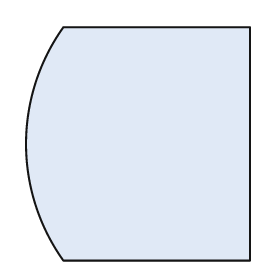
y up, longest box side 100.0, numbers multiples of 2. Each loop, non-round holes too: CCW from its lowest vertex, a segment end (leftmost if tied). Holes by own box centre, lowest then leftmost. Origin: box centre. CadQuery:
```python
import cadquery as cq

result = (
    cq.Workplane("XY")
    .moveTo(-32.0, -50.0)
    .lineTo(48.0, -50.0)
    .lineTo(48.0, 50.0)
    .lineTo(-32.0, 50.0)
    .threePointArc((-48.0, 0.0), (-32.0, -50.0))
    .close()
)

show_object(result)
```